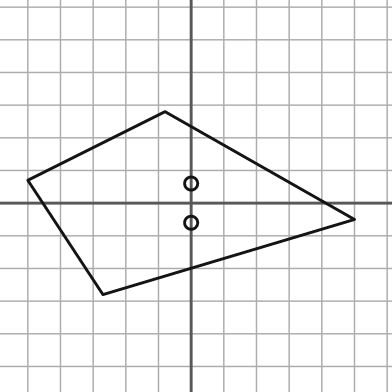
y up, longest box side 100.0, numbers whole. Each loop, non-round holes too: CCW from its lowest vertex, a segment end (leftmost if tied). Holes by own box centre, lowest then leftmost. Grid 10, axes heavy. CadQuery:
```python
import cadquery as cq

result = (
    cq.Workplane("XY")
    .moveTo(-27.0, -28.0)
    .lineTo(50.0, -5.0)
    .lineTo(-8.0, 28.0)
    .lineTo(-50.0, 7.0)
    .close()
    .moveTo(0.0, -6.0)
    .circle(2.0)
    .moveTo(0.0, 6.0)
    .circle(2.0)
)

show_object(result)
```